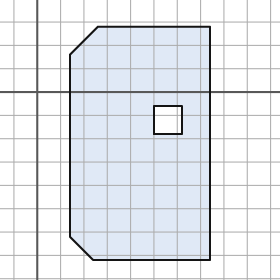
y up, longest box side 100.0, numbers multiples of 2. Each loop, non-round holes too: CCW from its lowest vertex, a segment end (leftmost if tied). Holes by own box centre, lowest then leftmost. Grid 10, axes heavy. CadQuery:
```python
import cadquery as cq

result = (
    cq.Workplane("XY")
    .moveTo(24.0, -72.0)
    .lineTo(74.0, -72.0)
    .lineTo(74.0, 28.0)
    .lineTo(26.0, 28.0)
    .lineTo(14.0, 16.0)
    .lineTo(14.0, -62.0)
    .close()
    .moveTo(50.0, -18.0)
    .lineTo(62.0, -18.0)
    .lineTo(62.0, -6.0)
    .lineTo(50.0, -6.0)
    .close()
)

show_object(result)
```